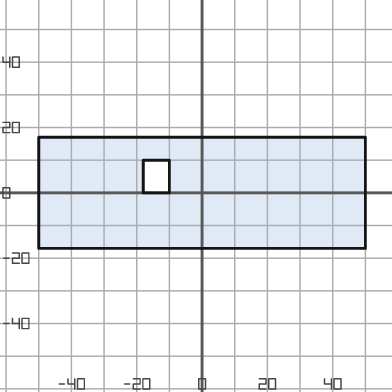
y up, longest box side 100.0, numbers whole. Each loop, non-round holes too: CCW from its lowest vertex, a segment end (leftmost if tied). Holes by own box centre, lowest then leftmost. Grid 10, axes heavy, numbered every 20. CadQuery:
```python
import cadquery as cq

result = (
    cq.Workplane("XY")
    .moveTo(-50.0, -17.0)
    .lineTo(50.0, -17.0)
    .lineTo(50.0, 17.0)
    .lineTo(-50.0, 17.0)
    .close()
    .moveTo(-18.0, 0.0)
    .lineTo(-10.0, 0.0)
    .lineTo(-10.0, 10.0)
    .lineTo(-18.0, 10.0)
    .close()
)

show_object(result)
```